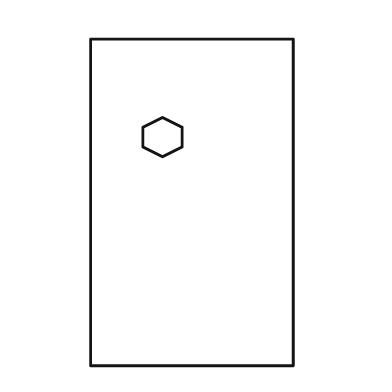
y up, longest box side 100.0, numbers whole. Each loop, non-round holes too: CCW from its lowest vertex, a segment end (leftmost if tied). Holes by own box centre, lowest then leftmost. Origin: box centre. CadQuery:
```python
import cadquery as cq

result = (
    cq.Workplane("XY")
    .moveTo(-31.0, -50.0)
    .lineTo(31.0, -50.0)
    .lineTo(31.0, 50.0)
    .lineTo(-31.0, 50.0)
    .close()
    .moveTo(-9.0, 14.0)
    .lineTo(-3.0, 17.0)
    .lineTo(-3.0, 23.0)
    .lineTo(-9.0, 26.0)
    .lineTo(-15.0, 23.0)
    .lineTo(-15.0, 17.0)
    .close()
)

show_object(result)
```